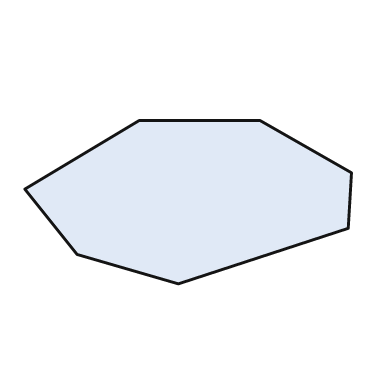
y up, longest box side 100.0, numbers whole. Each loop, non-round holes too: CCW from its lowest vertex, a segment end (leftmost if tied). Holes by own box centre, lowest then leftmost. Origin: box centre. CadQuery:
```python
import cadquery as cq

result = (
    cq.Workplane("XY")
    .moveTo(-3.0, -25.0)
    .lineTo(49.0, -8.0)
    .lineTo(50.0, 9.0)
    .lineTo(22.0, 25.0)
    .lineTo(-15.0, 25.0)
    .lineTo(-50.0, 4.0)
    .lineTo(-34.0, -16.0)
    .close()
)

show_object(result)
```